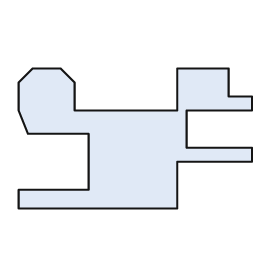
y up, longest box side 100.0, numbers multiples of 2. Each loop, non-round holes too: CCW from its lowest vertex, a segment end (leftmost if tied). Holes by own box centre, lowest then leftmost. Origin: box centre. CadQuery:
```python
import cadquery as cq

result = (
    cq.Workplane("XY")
    .moveTo(-50.0, -30.0)
    .lineTo(18.0, -30.0)
    .lineTo(18.0, -10.0)
    .lineTo(50.0, -10.0)
    .lineTo(50.0, -4.0)
    .lineTo(22.0, -4.0)
    .lineTo(22.0, 12.0)
    .lineTo(50.0, 12.0)
    .lineTo(50.0, 18.0)
    .lineTo(40.0, 18.0)
    .lineTo(40.0, 30.0)
    .lineTo(18.0, 30.0)
    .lineTo(18.0, 12.0)
    .lineTo(-26.0, 12.0)
    .lineTo(-26.0, 24.0)
    .lineTo(-32.0, 30.0)
    .lineTo(-44.0, 30.0)
    .lineTo(-50.0, 24.0)
    .lineTo(-50.0, 12.0)
    .lineTo(-46.0, 2.0)
    .lineTo(-20.0, 2.0)
    .lineTo(-20.0, -22.0)
    .lineTo(-50.0, -22.0)
    .close()
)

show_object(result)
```